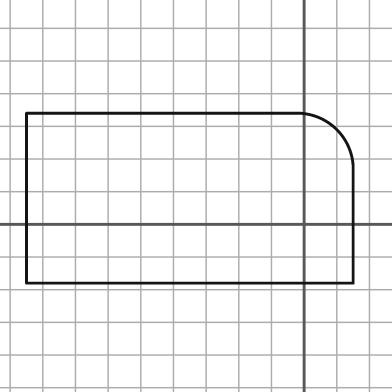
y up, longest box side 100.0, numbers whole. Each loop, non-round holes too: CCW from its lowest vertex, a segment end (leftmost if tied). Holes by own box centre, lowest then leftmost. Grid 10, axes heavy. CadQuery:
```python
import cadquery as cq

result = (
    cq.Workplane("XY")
    .moveTo(-85.0, -18.0)
    .lineTo(15.0, -18.0)
    .lineTo(15.0, 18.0)
    .threePointArc((10.0, 29.0), (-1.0, 34.0))
    .lineTo(-85.0, 34.0)
    .close()
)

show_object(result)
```